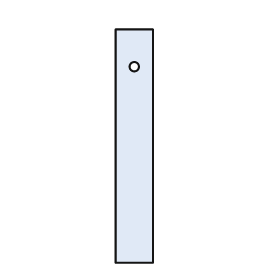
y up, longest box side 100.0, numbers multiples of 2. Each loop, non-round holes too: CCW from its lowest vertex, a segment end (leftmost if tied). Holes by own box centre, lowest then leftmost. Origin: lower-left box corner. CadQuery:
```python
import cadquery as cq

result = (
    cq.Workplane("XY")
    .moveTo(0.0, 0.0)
    .lineTo(16.0, 0.0)
    .lineTo(16.0, 100.0)
    .lineTo(0.0, 100.0)
    .close()
    .moveTo(8.0, 84.0)
    .circle(2.0)
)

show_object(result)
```